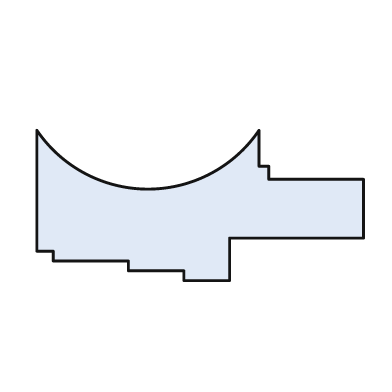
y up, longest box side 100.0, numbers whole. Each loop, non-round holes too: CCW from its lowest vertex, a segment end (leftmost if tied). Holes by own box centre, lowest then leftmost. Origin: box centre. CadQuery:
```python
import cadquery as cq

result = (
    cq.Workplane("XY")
    .moveTo(-5.0, -23.0)
    .lineTo(9.0, -23.0)
    .lineTo(9.0, -10.0)
    .lineTo(50.0, -10.0)
    .lineTo(50.0, 8.0)
    .lineTo(21.0, 8.0)
    .lineTo(21.0, 12.0)
    .lineTo(18.0, 12.0)
    .lineTo(18.0, 23.0)
    .threePointArc((-16.0, 5.0), (-50.0, 23.0))
    .lineTo(-50.0, -14.0)
    .lineTo(-45.0, -14.0)
    .lineTo(-45.0, -17.0)
    .lineTo(-22.0, -17.0)
    .lineTo(-22.0, -20.0)
    .lineTo(-5.0, -20.0)
    .close()
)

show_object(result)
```